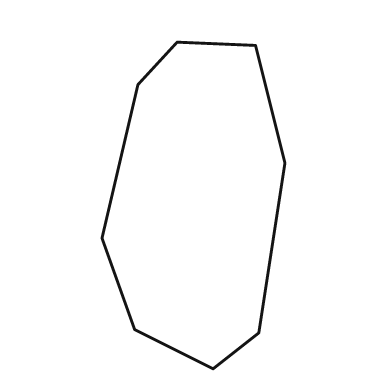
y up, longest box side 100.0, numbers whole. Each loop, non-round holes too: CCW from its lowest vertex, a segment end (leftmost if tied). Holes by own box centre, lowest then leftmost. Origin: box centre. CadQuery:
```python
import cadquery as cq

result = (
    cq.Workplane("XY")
    .moveTo(6.0, -50.0)
    .lineTo(20.0, -39.0)
    .lineTo(28.0, 13.0)
    .lineTo(19.0, 49.0)
    .lineTo(-5.0, 50.0)
    .lineTo(-17.0, 37.0)
    .lineTo(-28.0, -10.0)
    .lineTo(-18.0, -38.0)
    .close()
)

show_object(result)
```